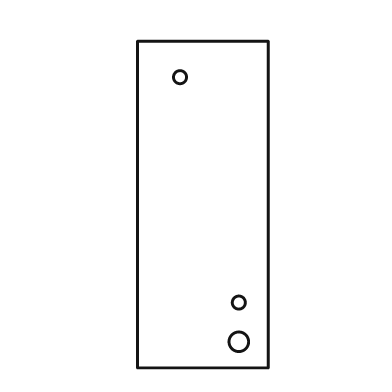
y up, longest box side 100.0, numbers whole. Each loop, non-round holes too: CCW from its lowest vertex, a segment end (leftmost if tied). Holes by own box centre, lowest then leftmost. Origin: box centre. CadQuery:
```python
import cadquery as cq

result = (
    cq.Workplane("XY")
    .moveTo(-20.0, -50.0)
    .lineTo(20.0, -50.0)
    .lineTo(20.0, 50.0)
    .lineTo(-20.0, 50.0)
    .close()
    .moveTo(11.0, -42.0)
    .circle(3.0)
    .moveTo(11.0, -30.0)
    .circle(2.0)
    .moveTo(-7.0, 39.0)
    .circle(2.0)
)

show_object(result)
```